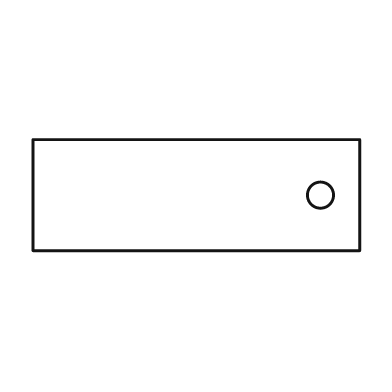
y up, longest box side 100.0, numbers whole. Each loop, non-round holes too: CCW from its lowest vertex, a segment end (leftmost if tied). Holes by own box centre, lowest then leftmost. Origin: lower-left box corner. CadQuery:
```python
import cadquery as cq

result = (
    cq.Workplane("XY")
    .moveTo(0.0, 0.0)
    .lineTo(100.0, 0.0)
    .lineTo(100.0, 34.0)
    .lineTo(0.0, 34.0)
    .close()
    .moveTo(88.0, 17.0)
    .circle(4.0)
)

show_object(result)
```